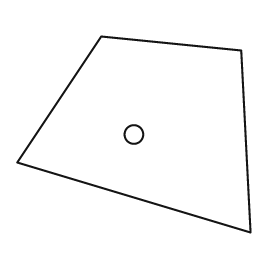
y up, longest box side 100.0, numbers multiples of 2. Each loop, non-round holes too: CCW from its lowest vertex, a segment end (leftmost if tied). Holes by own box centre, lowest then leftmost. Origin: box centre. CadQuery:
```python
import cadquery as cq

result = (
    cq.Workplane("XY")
    .moveTo(50.0, -42.0)
    .lineTo(46.0, 36.0)
    .lineTo(-14.0, 42.0)
    .lineTo(-50.0, -12.0)
    .close()
    .moveTo(0.0, 0.0)
    .circle(4.0)
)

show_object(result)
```